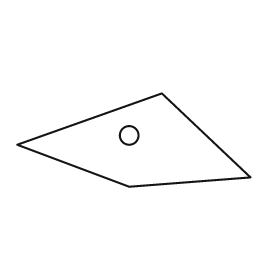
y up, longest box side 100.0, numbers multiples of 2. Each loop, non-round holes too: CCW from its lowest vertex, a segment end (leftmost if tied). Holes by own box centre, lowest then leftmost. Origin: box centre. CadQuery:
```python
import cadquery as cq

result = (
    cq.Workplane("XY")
    .moveTo(-2.0, -20.0)
    .lineTo(50.0, -16.0)
    .lineTo(12.0, 20.0)
    .lineTo(-50.0, -2.0)
    .close()
    .moveTo(-2.0, 2.0)
    .circle(4.0)
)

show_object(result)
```